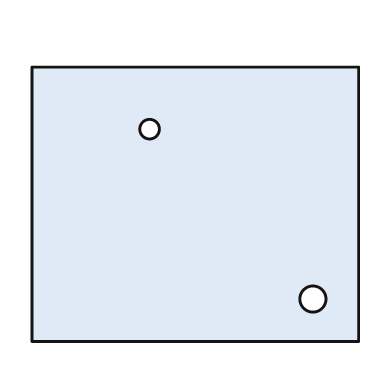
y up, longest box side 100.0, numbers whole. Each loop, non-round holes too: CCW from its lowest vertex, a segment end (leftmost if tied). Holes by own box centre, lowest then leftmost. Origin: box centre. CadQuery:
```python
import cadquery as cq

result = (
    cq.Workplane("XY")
    .moveTo(-50.0, -42.0)
    .lineTo(50.0, -42.0)
    .lineTo(50.0, 42.0)
    .lineTo(-50.0, 42.0)
    .close()
    .moveTo(36.0, -29.0)
    .circle(4.0)
    .moveTo(-14.0, 23.0)
    .circle(3.0)
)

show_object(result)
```